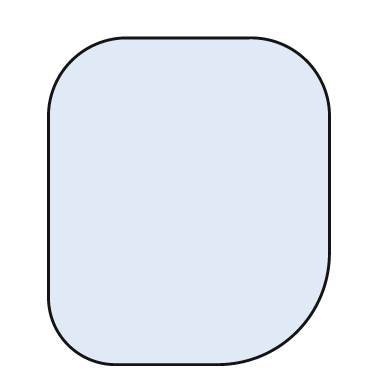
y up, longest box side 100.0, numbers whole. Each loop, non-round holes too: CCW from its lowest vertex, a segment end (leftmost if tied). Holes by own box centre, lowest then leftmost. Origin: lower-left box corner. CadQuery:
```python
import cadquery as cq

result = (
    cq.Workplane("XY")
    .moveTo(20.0, 0.0)
    .lineTo(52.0, 0.0)
    .threePointArc((76.0, 10.0), (86.0, 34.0))
    .lineTo(86.0, 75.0)
    .threePointArc((79.0, 93.0), (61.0, 100.0))
    .lineTo(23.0, 100.0)
    .threePointArc((7.0, 93.0), (0.0, 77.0))
    .lineTo(0.0, 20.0)
    .threePointArc((6.0, 6.0), (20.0, 0.0))
    .close()
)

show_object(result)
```